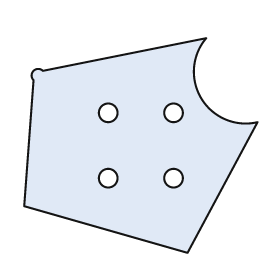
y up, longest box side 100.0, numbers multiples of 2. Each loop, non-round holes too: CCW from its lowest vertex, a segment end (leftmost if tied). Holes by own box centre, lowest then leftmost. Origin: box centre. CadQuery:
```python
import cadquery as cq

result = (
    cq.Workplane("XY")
    .moveTo(20.0, -46.0)
    .lineTo(50.0, 10.0)
    .threePointArc((26.0, 20.0), (28.0, 46.0))
    .lineTo(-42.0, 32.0)
    .threePointArc((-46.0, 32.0), (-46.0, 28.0))
    .lineTo(-50.0, -26.0)
    .close()
    .moveTo(-14.0, -14.0)
    .circle(4.0)
    .moveTo(14.0, -14.0)
    .circle(4.0)
    .moveTo(-14.0, 14.0)
    .circle(4.0)
    .moveTo(14.0, 14.0)
    .circle(4.0)
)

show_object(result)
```